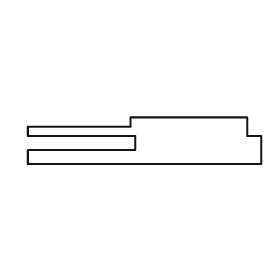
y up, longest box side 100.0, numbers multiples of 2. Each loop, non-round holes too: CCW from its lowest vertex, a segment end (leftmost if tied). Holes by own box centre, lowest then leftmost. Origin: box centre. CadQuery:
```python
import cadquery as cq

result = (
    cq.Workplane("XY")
    .moveTo(-50.0, -10.0)
    .lineTo(50.0, -10.0)
    .lineTo(50.0, 2.0)
    .lineTo(44.0, 2.0)
    .lineTo(44.0, 10.0)
    .lineTo(-6.0, 10.0)
    .lineTo(-6.0, 6.0)
    .lineTo(-50.0, 6.0)
    .lineTo(-50.0, 2.0)
    .lineTo(-4.0, 2.0)
    .lineTo(-4.0, -4.0)
    .lineTo(-50.0, -4.0)
    .close()
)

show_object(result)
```